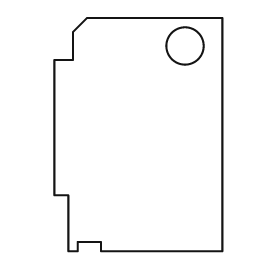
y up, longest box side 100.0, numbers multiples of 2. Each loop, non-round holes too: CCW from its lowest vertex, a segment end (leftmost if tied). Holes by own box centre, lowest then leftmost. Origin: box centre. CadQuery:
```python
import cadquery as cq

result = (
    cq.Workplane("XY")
    .moveTo(-30.0, -50.0)
    .lineTo(-26.0, -50.0)
    .lineTo(-26.0, -46.0)
    .lineTo(-16.0, -46.0)
    .lineTo(-16.0, -50.0)
    .lineTo(36.0, -50.0)
    .lineTo(36.0, 50.0)
    .lineTo(-22.0, 50.0)
    .lineTo(-28.0, 44.0)
    .lineTo(-28.0, 32.0)
    .lineTo(-36.0, 32.0)
    .lineTo(-36.0, -26.0)
    .lineTo(-30.0, -26.0)
    .close()
    .moveTo(20.0, 38.0)
    .circle(8.0)
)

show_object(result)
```